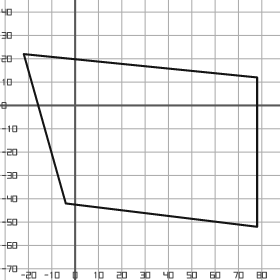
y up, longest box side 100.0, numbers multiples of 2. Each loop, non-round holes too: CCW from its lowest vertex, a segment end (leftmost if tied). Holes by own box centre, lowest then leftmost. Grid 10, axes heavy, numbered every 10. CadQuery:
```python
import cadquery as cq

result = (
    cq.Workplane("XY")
    .moveTo(78.0, -52.0)
    .lineTo(78.0, 12.0)
    .lineTo(-22.0, 22.0)
    .lineTo(-4.0, -42.0)
    .close()
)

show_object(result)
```